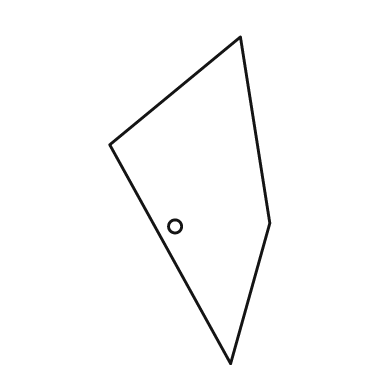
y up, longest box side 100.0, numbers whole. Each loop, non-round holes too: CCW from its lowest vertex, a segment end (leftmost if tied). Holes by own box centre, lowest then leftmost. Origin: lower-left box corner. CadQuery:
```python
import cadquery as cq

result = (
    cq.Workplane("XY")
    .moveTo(37.0, 0.0)
    .lineTo(49.0, 43.0)
    .lineTo(40.0, 100.0)
    .lineTo(0.0, 67.0)
    .close()
    .moveTo(20.0, 42.0)
    .circle(2.0)
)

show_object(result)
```